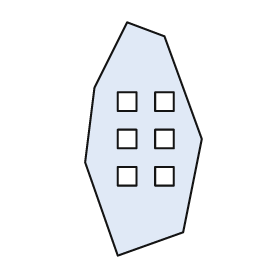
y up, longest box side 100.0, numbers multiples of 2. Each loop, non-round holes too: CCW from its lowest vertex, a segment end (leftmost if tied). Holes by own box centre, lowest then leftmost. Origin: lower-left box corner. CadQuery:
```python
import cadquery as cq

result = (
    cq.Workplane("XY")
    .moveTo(14.0, 0.0)
    .lineTo(42.0, 10.0)
    .lineTo(50.0, 50.0)
    .lineTo(34.0, 94.0)
    .lineTo(18.0, 100.0)
    .lineTo(4.0, 72.0)
    .lineTo(0.0, 40.0)
    .close()
    .moveTo(14.0, 30.0)
    .lineTo(22.0, 30.0)
    .lineTo(22.0, 38.0)
    .lineTo(14.0, 38.0)
    .close()
    .moveTo(30.0, 30.0)
    .lineTo(38.0, 30.0)
    .lineTo(38.0, 38.0)
    .lineTo(30.0, 38.0)
    .close()
    .moveTo(14.0, 46.0)
    .lineTo(22.0, 46.0)
    .lineTo(22.0, 54.0)
    .lineTo(14.0, 54.0)
    .close()
    .moveTo(30.0, 46.0)
    .lineTo(38.0, 46.0)
    .lineTo(38.0, 54.0)
    .lineTo(30.0, 54.0)
    .close()
    .moveTo(14.0, 62.0)
    .lineTo(22.0, 62.0)
    .lineTo(22.0, 70.0)
    .lineTo(14.0, 70.0)
    .close()
    .moveTo(30.0, 62.0)
    .lineTo(38.0, 62.0)
    .lineTo(38.0, 70.0)
    .lineTo(30.0, 70.0)
    .close()
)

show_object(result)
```